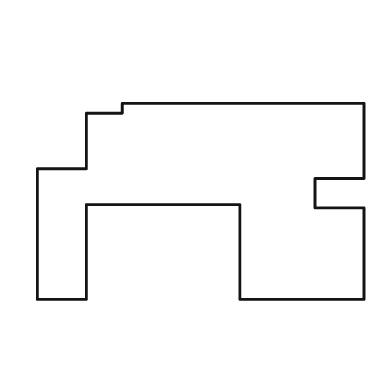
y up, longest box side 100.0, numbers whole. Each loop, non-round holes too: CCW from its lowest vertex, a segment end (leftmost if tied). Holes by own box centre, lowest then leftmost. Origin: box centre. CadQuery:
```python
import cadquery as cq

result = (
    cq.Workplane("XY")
    .moveTo(-50.0, -30.0)
    .lineTo(-35.0, -30.0)
    .lineTo(-35.0, -1.0)
    .lineTo(12.0, -1.0)
    .lineTo(12.0, -30.0)
    .lineTo(50.0, -30.0)
    .lineTo(50.0, -2.0)
    .lineTo(35.0, -2.0)
    .lineTo(35.0, 7.0)
    .lineTo(50.0, 7.0)
    .lineTo(50.0, 30.0)
    .lineTo(-24.0, 30.0)
    .lineTo(-24.0, 27.0)
    .lineTo(-35.0, 27.0)
    .lineTo(-35.0, 10.0)
    .lineTo(-50.0, 10.0)
    .close()
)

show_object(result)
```